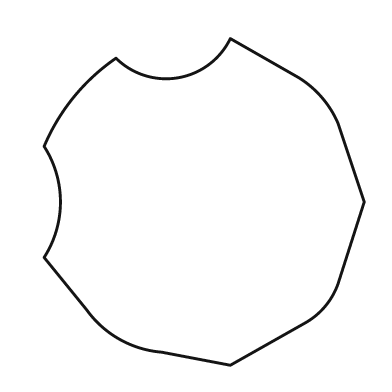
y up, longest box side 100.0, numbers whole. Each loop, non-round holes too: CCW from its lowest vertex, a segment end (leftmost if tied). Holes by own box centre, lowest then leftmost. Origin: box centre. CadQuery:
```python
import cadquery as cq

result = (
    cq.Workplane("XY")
    .moveTo(8.0, -50.0)
    .lineTo(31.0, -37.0)
    .threePointArc((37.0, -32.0), (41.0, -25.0))
    .lineTo(49.0, 0.0)
    .lineTo(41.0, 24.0)
    .threePointArc((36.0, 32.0), (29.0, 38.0))
    .lineTo(8.0, 50.0)
    .threePointArc((-8.0, 38.0), (-27.0, 44.0))
    .threePointArc((-40.0, 32.0), (-49.0, 17.0))
    .threePointArc((-44.0, 0.0), (-49.0, -17.0))
    .lineTo(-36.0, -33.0)
    .threePointArc((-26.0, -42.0), (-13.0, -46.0))
    .close()
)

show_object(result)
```